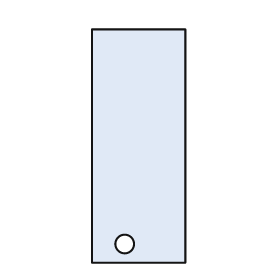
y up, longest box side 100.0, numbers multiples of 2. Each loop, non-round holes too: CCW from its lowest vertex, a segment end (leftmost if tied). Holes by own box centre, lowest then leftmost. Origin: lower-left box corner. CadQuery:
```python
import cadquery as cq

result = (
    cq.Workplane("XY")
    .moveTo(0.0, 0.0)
    .lineTo(40.0, 0.0)
    .lineTo(40.0, 100.0)
    .lineTo(0.0, 100.0)
    .close()
    .moveTo(14.0, 8.0)
    .circle(4.0)
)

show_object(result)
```